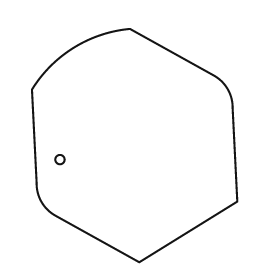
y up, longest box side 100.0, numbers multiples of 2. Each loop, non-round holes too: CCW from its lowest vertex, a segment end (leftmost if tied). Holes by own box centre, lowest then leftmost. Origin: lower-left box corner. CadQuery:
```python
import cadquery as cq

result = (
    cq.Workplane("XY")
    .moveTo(46.0, 0.0)
    .lineTo(88.0, 26.0)
    .lineTo(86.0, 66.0)
    .threePointArc((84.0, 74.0), (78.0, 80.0))
    .lineTo(42.0, 100.0)
    .threePointArc((18.0, 92.0), (0.0, 74.0))
    .lineTo(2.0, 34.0)
    .threePointArc((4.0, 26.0), (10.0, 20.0))
    .close()
    .moveTo(12.0, 44.0)
    .circle(2.0)
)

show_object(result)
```